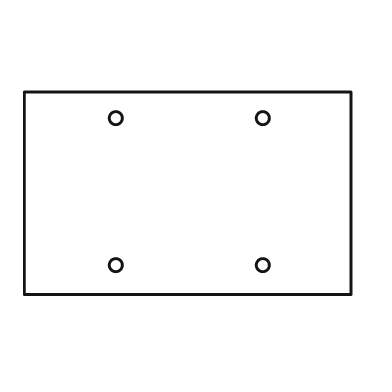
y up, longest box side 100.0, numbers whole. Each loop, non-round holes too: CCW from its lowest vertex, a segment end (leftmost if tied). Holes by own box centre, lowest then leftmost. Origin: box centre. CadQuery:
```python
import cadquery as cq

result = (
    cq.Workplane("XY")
    .moveTo(-50.0, -31.0)
    .lineTo(50.0, -31.0)
    .lineTo(50.0, 31.0)
    .lineTo(-50.0, 31.0)
    .close()
    .moveTo(-22.0, -22.0)
    .circle(2.0)
    .moveTo(23.0, -22.0)
    .circle(2.0)
    .moveTo(-22.0, 23.0)
    .circle(2.0)
    .moveTo(23.0, 23.0)
    .circle(2.0)
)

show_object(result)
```